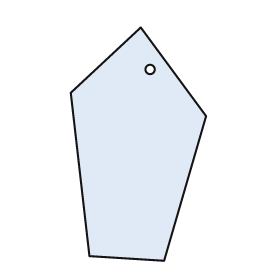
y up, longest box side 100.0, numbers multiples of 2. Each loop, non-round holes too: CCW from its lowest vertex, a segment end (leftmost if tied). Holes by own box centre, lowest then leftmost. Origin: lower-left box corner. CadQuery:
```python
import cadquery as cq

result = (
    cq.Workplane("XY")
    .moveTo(40.0, 0.0)
    .lineTo(58.0, 62.0)
    .lineTo(30.0, 100.0)
    .lineTo(0.0, 72.0)
    .lineTo(8.0, 2.0)
    .close()
    .moveTo(34.0, 82.0)
    .circle(2.0)
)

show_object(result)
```